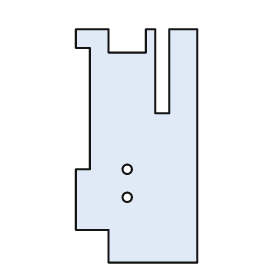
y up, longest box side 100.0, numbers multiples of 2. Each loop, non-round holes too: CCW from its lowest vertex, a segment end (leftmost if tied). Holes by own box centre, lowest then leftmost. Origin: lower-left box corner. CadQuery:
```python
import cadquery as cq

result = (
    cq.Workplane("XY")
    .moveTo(14.0, 0.0)
    .lineTo(52.0, 0.0)
    .lineTo(52.0, 100.0)
    .lineTo(40.0, 100.0)
    .lineTo(40.0, 64.0)
    .lineTo(34.0, 64.0)
    .lineTo(34.0, 100.0)
    .lineTo(30.0, 100.0)
    .lineTo(30.0, 90.0)
    .lineTo(14.0, 90.0)
    .lineTo(14.0, 100.0)
    .lineTo(0.0, 100.0)
    .lineTo(0.0, 92.0)
    .lineTo(6.0, 92.0)
    .lineTo(6.0, 40.0)
    .lineTo(0.0, 40.0)
    .lineTo(0.0, 14.0)
    .lineTo(14.0, 14.0)
    .close()
    .moveTo(22.0, 28.0)
    .circle(2.0)
    .moveTo(22.0, 40.0)
    .circle(2.0)
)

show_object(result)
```